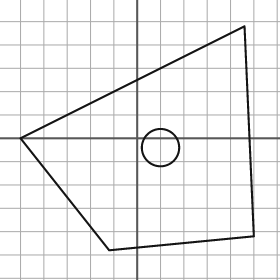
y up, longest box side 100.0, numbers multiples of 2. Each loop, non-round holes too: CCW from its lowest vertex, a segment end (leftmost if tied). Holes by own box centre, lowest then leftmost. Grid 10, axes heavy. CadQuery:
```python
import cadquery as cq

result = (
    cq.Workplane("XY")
    .moveTo(-12.0, -48.0)
    .lineTo(50.0, -42.0)
    .lineTo(46.0, 48.0)
    .lineTo(-50.0, 0.0)
    .close()
    .moveTo(10.0, -4.0)
    .circle(8.0)
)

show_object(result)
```